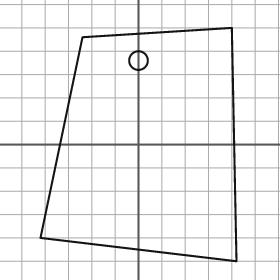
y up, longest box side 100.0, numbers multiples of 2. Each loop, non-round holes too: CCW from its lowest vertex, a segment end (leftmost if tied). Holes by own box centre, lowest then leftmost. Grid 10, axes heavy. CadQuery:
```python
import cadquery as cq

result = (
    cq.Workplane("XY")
    .moveTo(42.0, -50.0)
    .lineTo(40.0, 50.0)
    .lineTo(-24.0, 46.0)
    .lineTo(-42.0, -40.0)
    .close()
    .moveTo(0.0, 36.0)
    .circle(4.0)
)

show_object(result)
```